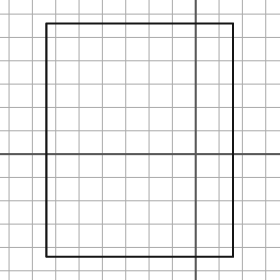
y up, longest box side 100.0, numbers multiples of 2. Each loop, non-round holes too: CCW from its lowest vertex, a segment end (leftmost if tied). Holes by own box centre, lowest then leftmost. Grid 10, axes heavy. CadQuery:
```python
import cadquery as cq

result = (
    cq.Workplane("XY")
    .moveTo(-64.0, -44.0)
    .lineTo(16.0, -44.0)
    .lineTo(16.0, 56.0)
    .lineTo(-64.0, 56.0)
    .close()
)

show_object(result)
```